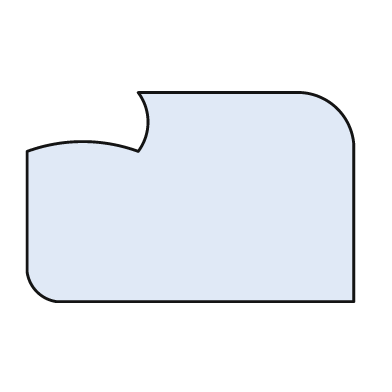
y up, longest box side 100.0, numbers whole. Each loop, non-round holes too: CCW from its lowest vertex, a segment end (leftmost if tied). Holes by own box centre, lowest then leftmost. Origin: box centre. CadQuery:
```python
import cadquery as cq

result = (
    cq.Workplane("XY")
    .moveTo(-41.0, -32.0)
    .lineTo(50.0, -32.0)
    .lineTo(50.0, 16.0)
    .threePointArc((45.0, 27.0), (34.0, 32.0))
    .lineTo(-16.0, 32.0)
    .threePointArc((-13.0, 23.0), (-16.0, 14.0))
    .threePointArc((-33.0, 17.0), (-50.0, 14.0))
    .lineTo(-50.0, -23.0)
    .threePointArc((-47.0, -29.0), (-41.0, -32.0))
    .close()
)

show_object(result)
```